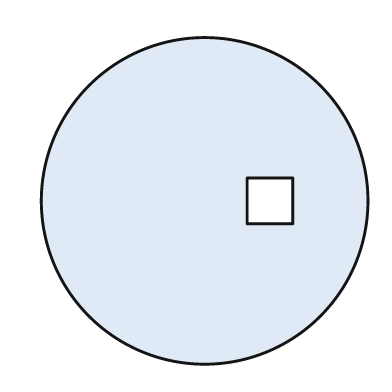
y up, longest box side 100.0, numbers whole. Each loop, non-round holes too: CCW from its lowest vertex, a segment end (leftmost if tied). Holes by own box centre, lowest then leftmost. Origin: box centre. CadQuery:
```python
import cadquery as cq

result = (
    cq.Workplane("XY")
    .moveTo(0.0, 0.0)
    .circle(50.0)
    .moveTo(13.0, -7.0)
    .lineTo(27.0, -7.0)
    .lineTo(27.0, 7.0)
    .lineTo(13.0, 7.0)
    .close()
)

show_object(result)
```